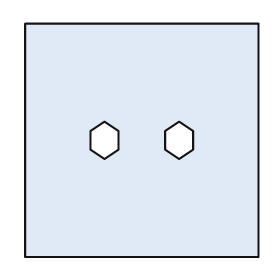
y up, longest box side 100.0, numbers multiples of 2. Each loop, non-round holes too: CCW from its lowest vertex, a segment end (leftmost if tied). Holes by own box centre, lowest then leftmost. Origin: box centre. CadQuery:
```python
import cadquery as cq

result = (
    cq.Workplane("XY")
    .moveTo(-50.0, -50.0)
    .lineTo(50.0, -50.0)
    .lineTo(50.0, 50.0)
    .lineTo(-50.0, 50.0)
    .close()
    .moveTo(-16.0, -8.0)
    .lineTo(-10.0, -4.0)
    .lineTo(-10.0, 4.0)
    .lineTo(-16.0, 8.0)
    .lineTo(-22.0, 4.0)
    .lineTo(-22.0, -4.0)
    .close()
    .moveTo(16.0, -8.0)
    .lineTo(22.0, -4.0)
    .lineTo(22.0, 4.0)
    .lineTo(16.0, 8.0)
    .lineTo(10.0, 4.0)
    .lineTo(10.0, -4.0)
    .close()
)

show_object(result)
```